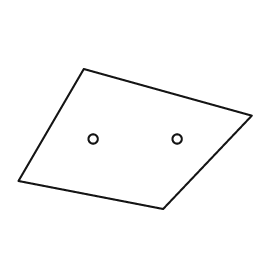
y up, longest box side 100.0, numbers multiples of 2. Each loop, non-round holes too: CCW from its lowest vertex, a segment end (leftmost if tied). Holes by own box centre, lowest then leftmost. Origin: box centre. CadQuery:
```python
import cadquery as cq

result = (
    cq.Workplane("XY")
    .moveTo(12.0, -30.0)
    .lineTo(50.0, 10.0)
    .lineTo(-22.0, 30.0)
    .lineTo(-50.0, -18.0)
    .close()
    .moveTo(-18.0, 0.0)
    .circle(2.0)
    .moveTo(18.0, 0.0)
    .circle(2.0)
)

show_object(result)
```